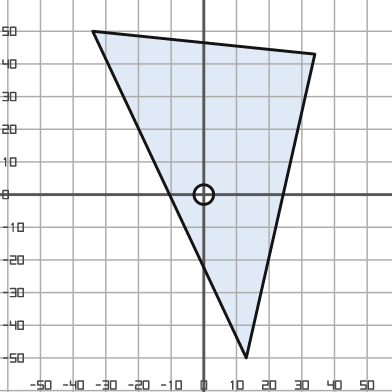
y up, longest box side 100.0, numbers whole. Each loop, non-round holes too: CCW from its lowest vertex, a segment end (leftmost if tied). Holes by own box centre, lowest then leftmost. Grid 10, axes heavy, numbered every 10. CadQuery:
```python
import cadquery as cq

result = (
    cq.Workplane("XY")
    .moveTo(13.0, -50.0)
    .lineTo(34.0, 43.0)
    .lineTo(-34.0, 50.0)
    .close()
    .moveTo(0.0, 0.0)
    .circle(3.0)
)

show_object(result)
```